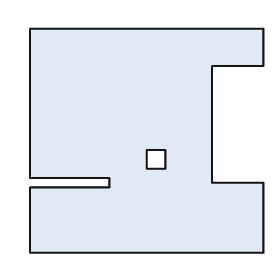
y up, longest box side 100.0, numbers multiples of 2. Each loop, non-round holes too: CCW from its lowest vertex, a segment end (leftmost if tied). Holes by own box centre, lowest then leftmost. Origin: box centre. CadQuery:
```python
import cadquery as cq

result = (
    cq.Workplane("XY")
    .moveTo(-50.0, -48.0)
    .lineTo(50.0, -48.0)
    .lineTo(50.0, -18.0)
    .lineTo(28.0, -18.0)
    .lineTo(28.0, 32.0)
    .lineTo(50.0, 32.0)
    .lineTo(50.0, 48.0)
    .lineTo(-50.0, 48.0)
    .lineTo(-50.0, -16.0)
    .lineTo(-16.0, -16.0)
    .lineTo(-16.0, -20.0)
    .lineTo(-50.0, -20.0)
    .close()
    .moveTo(0.0, -12.0)
    .lineTo(8.0, -12.0)
    .lineTo(8.0, -4.0)
    .lineTo(0.0, -4.0)
    .close()
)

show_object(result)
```